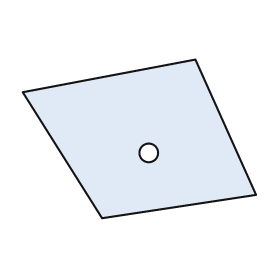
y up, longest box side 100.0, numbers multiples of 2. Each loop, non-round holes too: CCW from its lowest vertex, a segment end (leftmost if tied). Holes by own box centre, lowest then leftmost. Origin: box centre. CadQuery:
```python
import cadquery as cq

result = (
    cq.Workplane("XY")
    .moveTo(-16.0, -34.0)
    .lineTo(50.0, -24.0)
    .lineTo(24.0, 34.0)
    .lineTo(-50.0, 20.0)
    .close()
    .moveTo(4.0, -6.0)
    .circle(4.0)
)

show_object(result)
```